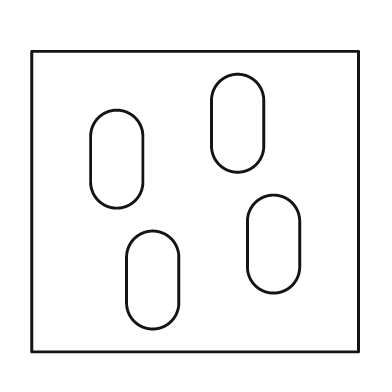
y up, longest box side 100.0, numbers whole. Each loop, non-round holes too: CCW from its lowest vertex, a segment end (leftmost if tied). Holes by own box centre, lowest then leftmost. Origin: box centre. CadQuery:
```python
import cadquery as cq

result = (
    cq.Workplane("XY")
    .moveTo(-50.0, -46.0)
    .lineTo(50.0, -46.0)
    .lineTo(50.0, 46.0)
    .lineTo(-50.0, 46.0)
    .close()
    .moveTo(-21.0, -31.0)
    .threePointArc((-13.0, -39.0), (-5.0, -31.0))
    .lineTo(-5.0, -17.0)
    .threePointArc((-13.0, -9.0), (-21.0, -17.0))
    .close()
    .moveTo(16.0, -20.0)
    .threePointArc((24.0, -28.0), (32.0, -20.0))
    .lineTo(32.0, -6.0)
    .threePointArc((24.0, 2.0), (16.0, -6.0))
    .close()
    .moveTo(-32.0, 6.0)
    .threePointArc((-24.0, -2.0), (-16.0, 6.0))
    .lineTo(-16.0, 20.0)
    .threePointArc((-24.0, 28.0), (-32.0, 20.0))
    .close()
    .moveTo(5.0, 17.0)
    .threePointArc((13.0, 9.0), (21.0, 17.0))
    .lineTo(21.0, 31.0)
    .threePointArc((13.0, 39.0), (5.0, 31.0))
    .close()
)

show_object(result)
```